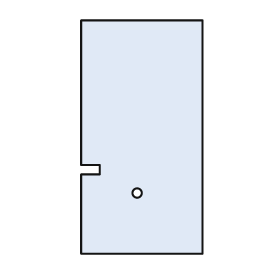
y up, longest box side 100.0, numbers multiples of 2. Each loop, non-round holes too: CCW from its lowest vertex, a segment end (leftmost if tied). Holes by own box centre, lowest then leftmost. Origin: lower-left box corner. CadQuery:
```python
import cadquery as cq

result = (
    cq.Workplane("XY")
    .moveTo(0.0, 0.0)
    .lineTo(52.0, 0.0)
    .lineTo(52.0, 100.0)
    .lineTo(0.0, 100.0)
    .lineTo(0.0, 38.0)
    .lineTo(8.0, 38.0)
    .lineTo(8.0, 34.0)
    .lineTo(0.0, 34.0)
    .close()
    .moveTo(24.0, 26.0)
    .circle(2.0)
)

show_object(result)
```